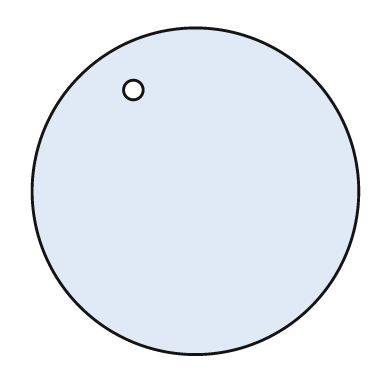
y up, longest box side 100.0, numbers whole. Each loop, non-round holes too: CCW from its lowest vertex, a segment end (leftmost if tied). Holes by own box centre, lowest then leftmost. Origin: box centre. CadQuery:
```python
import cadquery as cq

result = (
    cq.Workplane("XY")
    .moveTo(0.0, 0.0)
    .circle(50.0)
    .moveTo(-19.0, 31.0)
    .circle(3.0)
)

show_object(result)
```